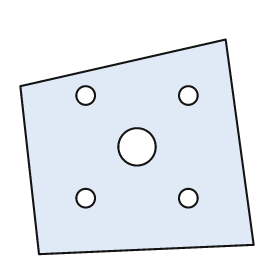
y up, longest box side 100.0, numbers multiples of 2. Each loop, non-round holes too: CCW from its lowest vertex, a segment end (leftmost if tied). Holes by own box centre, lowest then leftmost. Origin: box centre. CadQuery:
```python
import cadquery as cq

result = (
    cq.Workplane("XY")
    .moveTo(-42.0, -46.0)
    .lineTo(50.0, -42.0)
    .lineTo(38.0, 46.0)
    .lineTo(-50.0, 26.0)
    .close()
    .moveTo(-22.0, -22.0)
    .circle(4.0)
    .moveTo(22.0, -22.0)
    .circle(4.0)
    .moveTo(0.0, 0.0)
    .circle(8.0)
    .moveTo(-22.0, 22.0)
    .circle(4.0)
    .moveTo(22.0, 22.0)
    .circle(4.0)
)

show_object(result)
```